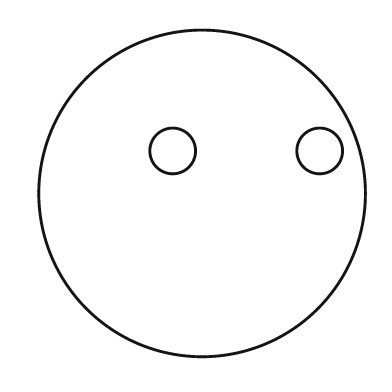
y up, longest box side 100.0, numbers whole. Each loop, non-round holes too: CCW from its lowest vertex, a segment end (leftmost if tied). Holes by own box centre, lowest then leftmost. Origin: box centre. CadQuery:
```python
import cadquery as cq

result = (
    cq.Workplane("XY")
    .moveTo(0.0, 0.0)
    .circle(50.0)
    .moveTo(-9.0, 13.0)
    .circle(7.0)
    .moveTo(36.0, 13.0)
    .circle(7.0)
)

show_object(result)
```